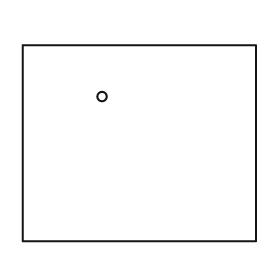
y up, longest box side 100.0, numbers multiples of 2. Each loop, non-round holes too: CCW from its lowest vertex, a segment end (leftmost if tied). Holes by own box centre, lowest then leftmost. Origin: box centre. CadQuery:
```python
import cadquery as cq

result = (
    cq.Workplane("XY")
    .moveTo(-50.0, -42.0)
    .lineTo(50.0, -42.0)
    .lineTo(50.0, 42.0)
    .lineTo(-50.0, 42.0)
    .close()
    .moveTo(-16.0, 20.0)
    .circle(2.0)
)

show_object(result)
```